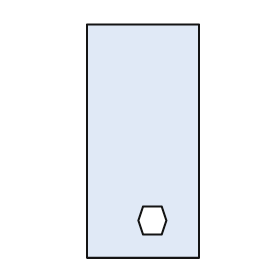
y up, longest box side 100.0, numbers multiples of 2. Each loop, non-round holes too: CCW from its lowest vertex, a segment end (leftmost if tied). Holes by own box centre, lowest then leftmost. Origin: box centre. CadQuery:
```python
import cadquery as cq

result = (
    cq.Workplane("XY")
    .moveTo(-24.0, -50.0)
    .lineTo(24.0, -50.0)
    .lineTo(24.0, 50.0)
    .lineTo(-24.0, 50.0)
    .close()
    .moveTo(0.0, -40.0)
    .lineTo(8.0, -40.0)
    .lineTo(10.0, -34.0)
    .lineTo(8.0, -28.0)
    .lineTo(0.0, -28.0)
    .lineTo(-2.0, -34.0)
    .close()
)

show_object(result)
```